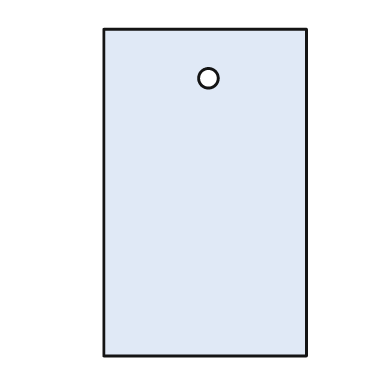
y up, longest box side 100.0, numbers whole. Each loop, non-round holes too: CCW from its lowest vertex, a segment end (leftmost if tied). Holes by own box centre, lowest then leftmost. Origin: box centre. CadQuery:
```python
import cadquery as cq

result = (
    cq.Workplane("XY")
    .moveTo(-31.0, -50.0)
    .lineTo(31.0, -50.0)
    .lineTo(31.0, 50.0)
    .lineTo(-31.0, 50.0)
    .close()
    .moveTo(1.0, 35.0)
    .circle(3.0)
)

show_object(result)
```